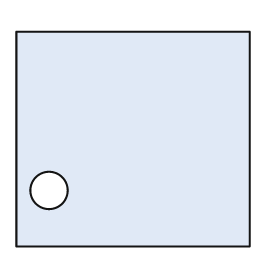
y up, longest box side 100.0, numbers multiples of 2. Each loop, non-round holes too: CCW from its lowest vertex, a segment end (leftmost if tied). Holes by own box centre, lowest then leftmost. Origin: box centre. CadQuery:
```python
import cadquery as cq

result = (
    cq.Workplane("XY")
    .moveTo(-50.0, -46.0)
    .lineTo(50.0, -46.0)
    .lineTo(50.0, 46.0)
    .lineTo(-50.0, 46.0)
    .close()
    .moveTo(-36.0, -22.0)
    .circle(8.0)
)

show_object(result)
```